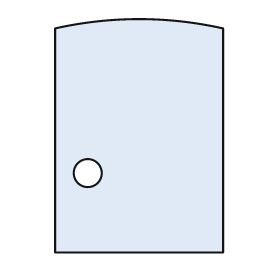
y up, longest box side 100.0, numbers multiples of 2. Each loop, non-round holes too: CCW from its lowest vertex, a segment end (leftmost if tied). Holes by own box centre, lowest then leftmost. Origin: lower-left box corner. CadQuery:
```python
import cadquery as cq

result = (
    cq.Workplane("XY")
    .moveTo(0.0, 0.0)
    .lineTo(72.0, 0.0)
    .lineTo(72.0, 96.0)
    .threePointArc((36.0, 100.0), (0.0, 96.0))
    .close()
    .moveTo(14.0, 34.0)
    .circle(6.0)
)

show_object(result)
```